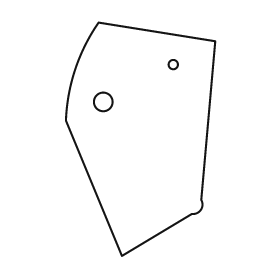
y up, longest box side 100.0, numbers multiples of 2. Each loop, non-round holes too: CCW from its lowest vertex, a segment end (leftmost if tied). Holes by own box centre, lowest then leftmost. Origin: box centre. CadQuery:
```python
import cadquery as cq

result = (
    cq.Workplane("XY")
    .moveTo(-8.0, -50.0)
    .lineTo(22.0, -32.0)
    .threePointArc((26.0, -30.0), (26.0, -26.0))
    .lineTo(32.0, 42.0)
    .lineTo(-18.0, 50.0)
    .threePointArc((-28.0, 30.0), (-32.0, 8.0))
    .close()
    .moveTo(-16.0, 16.0)
    .circle(4.0)
    .moveTo(14.0, 32.0)
    .circle(2.0)
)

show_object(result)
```